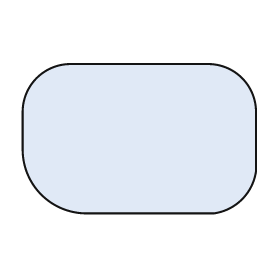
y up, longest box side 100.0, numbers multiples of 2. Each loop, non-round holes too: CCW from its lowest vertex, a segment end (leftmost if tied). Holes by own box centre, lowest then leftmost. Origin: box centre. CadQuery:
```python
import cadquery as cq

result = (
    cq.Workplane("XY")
    .moveTo(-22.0, -32.0)
    .lineTo(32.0, -32.0)
    .threePointArc((44.0, -26.0), (50.0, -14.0))
    .lineTo(50.0, 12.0)
    .threePointArc((44.0, 26.0), (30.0, 32.0))
    .lineTo(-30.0, 32.0)
    .threePointArc((-44.0, 26.0), (-50.0, 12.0))
    .lineTo(-50.0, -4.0)
    .threePointArc((-42.0, -24.0), (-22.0, -32.0))
    .close()
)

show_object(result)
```